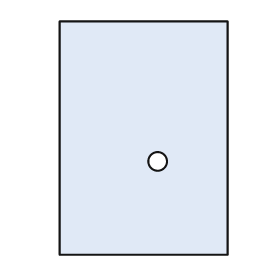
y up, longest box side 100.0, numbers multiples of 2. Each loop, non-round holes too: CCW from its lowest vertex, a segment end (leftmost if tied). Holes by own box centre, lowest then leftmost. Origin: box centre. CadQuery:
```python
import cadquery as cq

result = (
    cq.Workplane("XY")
    .moveTo(-36.0, -50.0)
    .lineTo(36.0, -50.0)
    .lineTo(36.0, 50.0)
    .lineTo(-36.0, 50.0)
    .close()
    .moveTo(6.0, -10.0)
    .circle(4.0)
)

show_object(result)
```